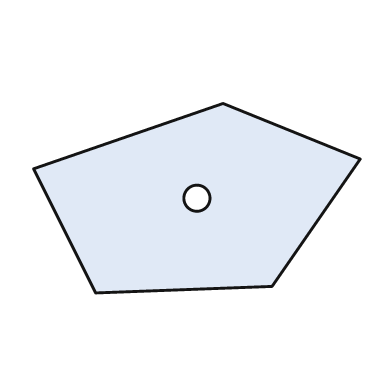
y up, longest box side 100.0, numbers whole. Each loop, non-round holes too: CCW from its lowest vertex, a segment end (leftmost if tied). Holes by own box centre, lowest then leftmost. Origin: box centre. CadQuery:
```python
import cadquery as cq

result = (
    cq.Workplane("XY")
    .moveTo(-31.0, -29.0)
    .lineTo(23.0, -27.0)
    .lineTo(50.0, 12.0)
    .lineTo(8.0, 29.0)
    .lineTo(-50.0, 9.0)
    .close()
    .moveTo(0.0, 0.0)
    .circle(4.0)
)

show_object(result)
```